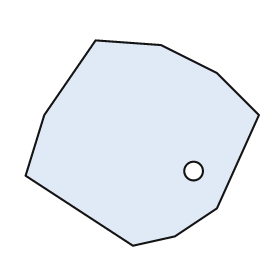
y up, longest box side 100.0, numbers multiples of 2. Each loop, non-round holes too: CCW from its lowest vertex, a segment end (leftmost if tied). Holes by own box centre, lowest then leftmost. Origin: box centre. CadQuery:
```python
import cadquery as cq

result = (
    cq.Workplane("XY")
    .moveTo(-4.0, -44.0)
    .lineTo(14.0, -40.0)
    .lineTo(32.0, -28.0)
    .lineTo(50.0, 12.0)
    .lineTo(32.0, 30.0)
    .lineTo(8.0, 42.0)
    .lineTo(-20.0, 44.0)
    .lineTo(-42.0, 12.0)
    .lineTo(-50.0, -14.0)
    .close()
    .moveTo(22.0, -12.0)
    .circle(4.0)
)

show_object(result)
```